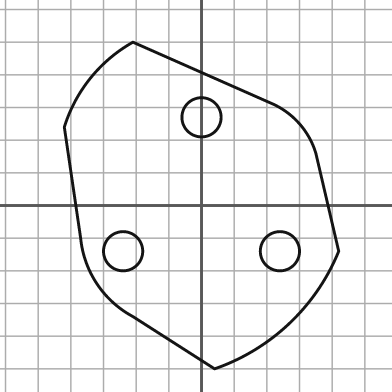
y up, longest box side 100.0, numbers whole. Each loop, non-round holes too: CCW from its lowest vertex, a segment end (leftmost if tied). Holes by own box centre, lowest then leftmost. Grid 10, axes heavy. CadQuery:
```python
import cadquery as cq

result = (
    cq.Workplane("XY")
    .moveTo(4.0, -50.0)
    .threePointArc((27.0, -36.0), (42.0, -14.0))
    .lineTo(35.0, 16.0)
    .threePointArc((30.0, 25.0), (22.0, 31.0))
    .lineTo(-21.0, 50.0)
    .threePointArc((-34.0, 39.0), (-42.0, 24.0))
    .lineTo(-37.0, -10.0)
    .threePointArc((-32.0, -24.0), (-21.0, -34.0))
    .close()
    .moveTo(-24.0, -14.0)
    .circle(6.0)
    .moveTo(24.0, -14.0)
    .circle(6.0)
    .moveTo(0.0, 27.0)
    .circle(6.0)
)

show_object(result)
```